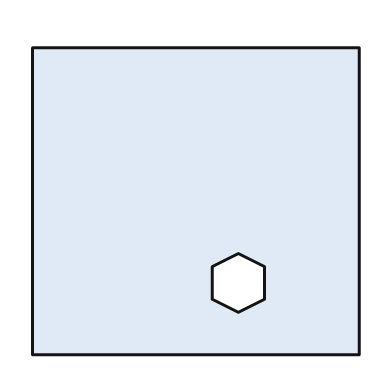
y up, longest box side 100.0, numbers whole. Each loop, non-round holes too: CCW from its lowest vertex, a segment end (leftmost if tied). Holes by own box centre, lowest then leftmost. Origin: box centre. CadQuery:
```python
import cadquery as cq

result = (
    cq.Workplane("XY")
    .moveTo(-50.0, -47.0)
    .lineTo(50.0, -47.0)
    .lineTo(50.0, 47.0)
    .lineTo(-50.0, 47.0)
    .close()
    .moveTo(13.0, -34.0)
    .lineTo(21.0, -30.0)
    .lineTo(21.0, -20.0)
    .lineTo(13.0, -16.0)
    .lineTo(5.0, -20.0)
    .lineTo(5.0, -30.0)
    .close()
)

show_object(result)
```